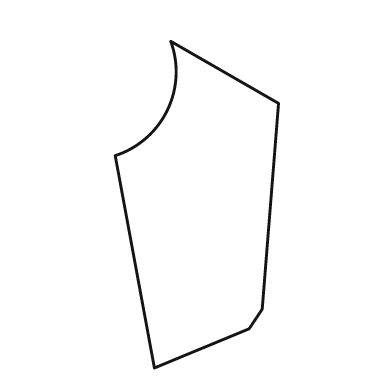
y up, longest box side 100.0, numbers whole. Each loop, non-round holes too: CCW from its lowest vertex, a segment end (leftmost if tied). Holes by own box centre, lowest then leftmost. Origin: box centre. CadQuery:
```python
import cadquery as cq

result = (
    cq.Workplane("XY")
    .moveTo(-13.0, -50.0)
    .lineTo(16.0, -38.0)
    .lineTo(20.0, -32.0)
    .lineTo(25.0, 31.0)
    .lineTo(-8.0, 50.0)
    .threePointArc((-9.0, 29.0), (-25.0, 15.0))
    .close()
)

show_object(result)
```